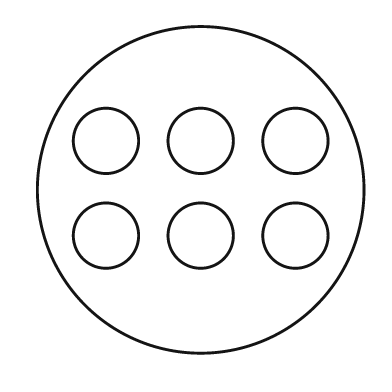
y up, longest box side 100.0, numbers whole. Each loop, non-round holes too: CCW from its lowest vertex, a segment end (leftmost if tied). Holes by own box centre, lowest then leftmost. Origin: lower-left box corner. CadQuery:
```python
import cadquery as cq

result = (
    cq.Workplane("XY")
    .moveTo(50.0, 50.0)
    .circle(50.0)
    .moveTo(21.0, 36.0)
    .circle(10.0)
    .moveTo(50.0, 36.0)
    .circle(10.0)
    .moveTo(79.0, 36.0)
    .circle(10.0)
    .moveTo(21.0, 65.0)
    .circle(10.0)
    .moveTo(50.0, 65.0)
    .circle(10.0)
    .moveTo(79.0, 65.0)
    .circle(10.0)
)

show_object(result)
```